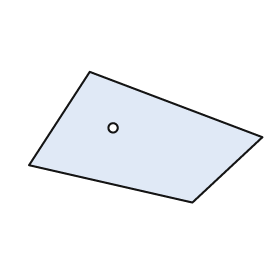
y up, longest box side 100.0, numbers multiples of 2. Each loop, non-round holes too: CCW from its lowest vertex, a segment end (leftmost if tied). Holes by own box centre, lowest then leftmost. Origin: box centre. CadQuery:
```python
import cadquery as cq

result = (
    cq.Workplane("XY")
    .moveTo(20.0, -28.0)
    .lineTo(50.0, 0.0)
    .lineTo(-24.0, 28.0)
    .lineTo(-50.0, -12.0)
    .close()
    .moveTo(-14.0, 4.0)
    .circle(2.0)
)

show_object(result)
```